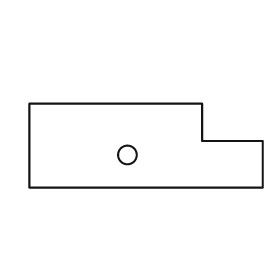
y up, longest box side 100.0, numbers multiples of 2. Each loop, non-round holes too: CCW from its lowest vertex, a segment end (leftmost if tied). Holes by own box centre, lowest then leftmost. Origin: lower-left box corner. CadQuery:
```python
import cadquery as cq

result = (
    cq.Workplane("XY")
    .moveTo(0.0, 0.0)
    .lineTo(100.0, 0.0)
    .lineTo(100.0, 20.0)
    .lineTo(74.0, 20.0)
    .lineTo(74.0, 36.0)
    .lineTo(0.0, 36.0)
    .close()
    .moveTo(42.0, 14.0)
    .circle(4.0)
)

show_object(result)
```